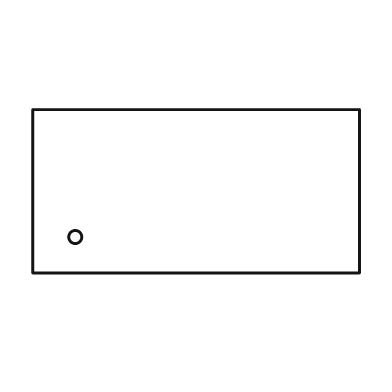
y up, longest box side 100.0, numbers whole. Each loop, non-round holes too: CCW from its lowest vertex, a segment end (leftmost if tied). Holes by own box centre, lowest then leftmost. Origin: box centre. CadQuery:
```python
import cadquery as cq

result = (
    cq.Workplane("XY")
    .moveTo(-50.0, -25.0)
    .lineTo(50.0, -25.0)
    .lineTo(50.0, 25.0)
    .lineTo(-50.0, 25.0)
    .close()
    .moveTo(-37.0, -14.0)
    .circle(2.0)
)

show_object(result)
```